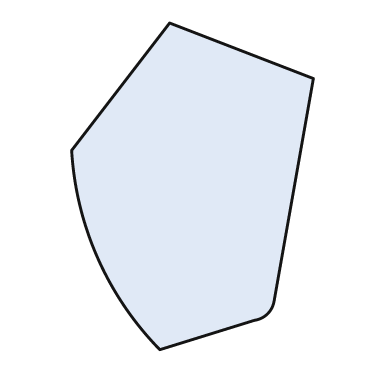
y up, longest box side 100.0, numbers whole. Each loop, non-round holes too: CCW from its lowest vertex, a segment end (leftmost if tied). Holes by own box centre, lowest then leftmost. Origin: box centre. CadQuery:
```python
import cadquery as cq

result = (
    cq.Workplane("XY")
    .moveTo(-10.0, -50.0)
    .lineTo(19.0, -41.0)
    .threePointArc((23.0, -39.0), (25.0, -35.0))
    .lineTo(37.0, 33.0)
    .lineTo(-7.0, 50.0)
    .lineTo(-37.0, 11.0)
    .threePointArc((-29.0, -22.0), (-10.0, -50.0))
    .close()
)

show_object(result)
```